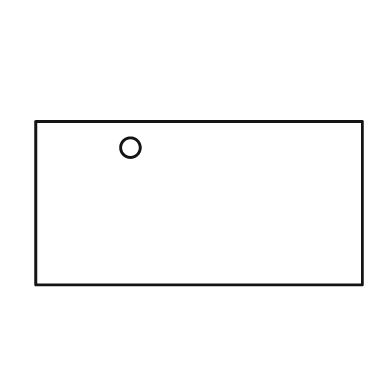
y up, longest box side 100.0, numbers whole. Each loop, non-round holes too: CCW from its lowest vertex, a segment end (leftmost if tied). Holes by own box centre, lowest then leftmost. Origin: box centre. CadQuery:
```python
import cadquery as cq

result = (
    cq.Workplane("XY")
    .moveTo(-50.0, -25.0)
    .lineTo(50.0, -25.0)
    .lineTo(50.0, 25.0)
    .lineTo(-50.0, 25.0)
    .close()
    .moveTo(-21.0, 17.0)
    .circle(3.0)
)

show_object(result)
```